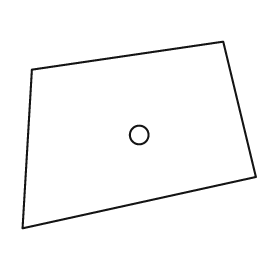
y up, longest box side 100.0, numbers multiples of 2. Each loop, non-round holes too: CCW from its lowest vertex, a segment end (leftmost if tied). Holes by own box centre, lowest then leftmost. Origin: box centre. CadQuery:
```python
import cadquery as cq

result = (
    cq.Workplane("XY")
    .moveTo(-50.0, -40.0)
    .lineTo(50.0, -18.0)
    .lineTo(36.0, 40.0)
    .lineTo(-46.0, 28.0)
    .close()
    .moveTo(0.0, 0.0)
    .circle(4.0)
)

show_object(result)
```